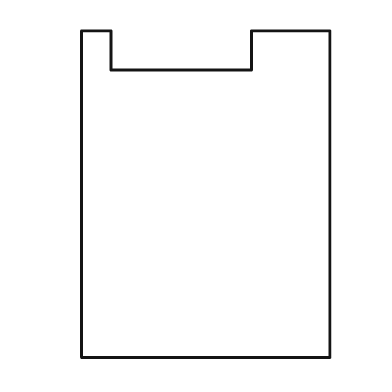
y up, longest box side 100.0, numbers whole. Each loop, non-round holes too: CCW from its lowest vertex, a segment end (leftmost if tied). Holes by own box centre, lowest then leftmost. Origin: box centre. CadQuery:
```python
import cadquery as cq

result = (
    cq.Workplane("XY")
    .moveTo(-38.0, -50.0)
    .lineTo(38.0, -50.0)
    .lineTo(38.0, 50.0)
    .lineTo(14.0, 50.0)
    .lineTo(14.0, 38.0)
    .lineTo(-29.0, 38.0)
    .lineTo(-29.0, 50.0)
    .lineTo(-38.0, 50.0)
    .close()
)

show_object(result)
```